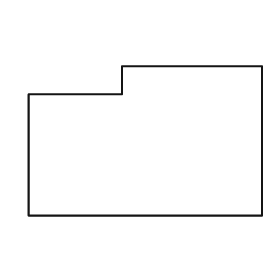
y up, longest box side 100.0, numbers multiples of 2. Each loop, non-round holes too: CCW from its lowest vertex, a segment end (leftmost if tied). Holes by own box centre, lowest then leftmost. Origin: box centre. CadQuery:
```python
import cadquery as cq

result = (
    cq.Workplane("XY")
    .moveTo(-50.0, -32.0)
    .lineTo(50.0, -32.0)
    .lineTo(50.0, 32.0)
    .lineTo(-10.0, 32.0)
    .lineTo(-10.0, 20.0)
    .lineTo(-50.0, 20.0)
    .close()
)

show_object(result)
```